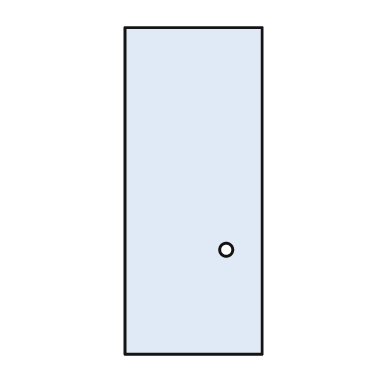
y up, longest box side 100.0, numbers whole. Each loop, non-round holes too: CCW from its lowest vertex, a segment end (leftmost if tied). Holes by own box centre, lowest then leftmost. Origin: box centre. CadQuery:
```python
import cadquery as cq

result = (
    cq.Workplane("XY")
    .moveTo(-21.0, -50.0)
    .lineTo(21.0, -50.0)
    .lineTo(21.0, 50.0)
    .lineTo(-21.0, 50.0)
    .close()
    .moveTo(10.0, -18.0)
    .circle(2.0)
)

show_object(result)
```